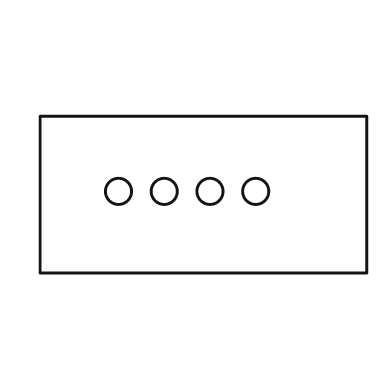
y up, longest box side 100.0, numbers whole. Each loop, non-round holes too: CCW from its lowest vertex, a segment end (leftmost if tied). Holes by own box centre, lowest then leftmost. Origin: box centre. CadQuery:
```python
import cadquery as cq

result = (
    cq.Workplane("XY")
    .moveTo(-50.0, -24.0)
    .lineTo(50.0, -24.0)
    .lineTo(50.0, 24.0)
    .lineTo(-50.0, 24.0)
    .close()
    .moveTo(-26.0, 1.0)
    .circle(4.0)
    .moveTo(-12.0, 1.0)
    .circle(4.0)
    .moveTo(2.0, 1.0)
    .circle(4.0)
    .moveTo(16.0, 1.0)
    .circle(4.0)
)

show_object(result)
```